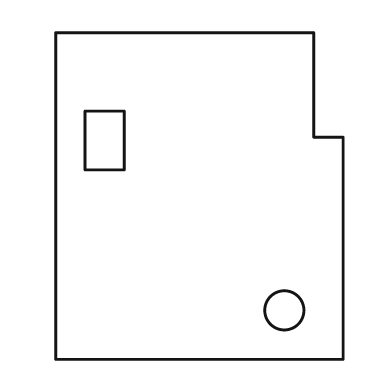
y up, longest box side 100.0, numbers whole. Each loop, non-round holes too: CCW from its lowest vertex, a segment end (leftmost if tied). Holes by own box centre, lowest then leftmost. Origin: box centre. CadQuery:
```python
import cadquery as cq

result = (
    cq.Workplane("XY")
    .moveTo(-44.0, -50.0)
    .lineTo(44.0, -50.0)
    .lineTo(44.0, 18.0)
    .lineTo(35.0, 18.0)
    .lineTo(35.0, 50.0)
    .lineTo(-44.0, 50.0)
    .close()
    .moveTo(26.0, -35.0)
    .circle(6.0)
    .moveTo(-35.0, 8.0)
    .lineTo(-23.0, 8.0)
    .lineTo(-23.0, 26.0)
    .lineTo(-35.0, 26.0)
    .close()
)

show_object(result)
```